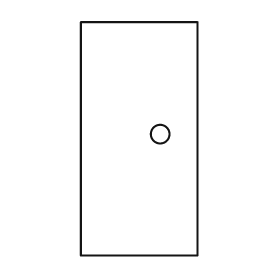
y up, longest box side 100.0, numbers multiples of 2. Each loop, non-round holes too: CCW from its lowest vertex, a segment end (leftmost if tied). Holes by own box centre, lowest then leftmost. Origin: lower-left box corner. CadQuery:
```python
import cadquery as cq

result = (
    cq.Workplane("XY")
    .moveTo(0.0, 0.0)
    .lineTo(50.0, 0.0)
    .lineTo(50.0, 100.0)
    .lineTo(0.0, 100.0)
    .close()
    .moveTo(34.0, 52.0)
    .circle(4.0)
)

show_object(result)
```